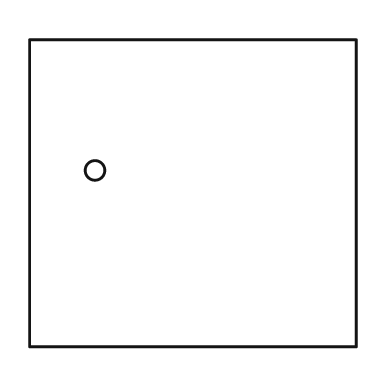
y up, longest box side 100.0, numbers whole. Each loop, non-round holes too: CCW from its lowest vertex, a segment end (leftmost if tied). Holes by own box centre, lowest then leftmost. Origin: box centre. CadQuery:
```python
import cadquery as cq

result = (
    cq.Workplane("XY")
    .moveTo(-50.0, -47.0)
    .lineTo(50.0, -47.0)
    .lineTo(50.0, 47.0)
    .lineTo(-50.0, 47.0)
    .close()
    .moveTo(-30.0, 7.0)
    .circle(3.0)
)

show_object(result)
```